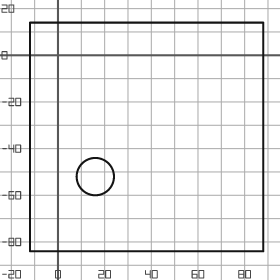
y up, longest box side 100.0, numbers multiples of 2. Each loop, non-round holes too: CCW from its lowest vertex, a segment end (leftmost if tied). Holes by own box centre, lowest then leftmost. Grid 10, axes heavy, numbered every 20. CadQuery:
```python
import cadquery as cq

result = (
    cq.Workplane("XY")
    .moveTo(-12.0, -84.0)
    .lineTo(88.0, -84.0)
    .lineTo(88.0, 14.0)
    .lineTo(-12.0, 14.0)
    .close()
    .moveTo(16.0, -52.0)
    .circle(8.0)
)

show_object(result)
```